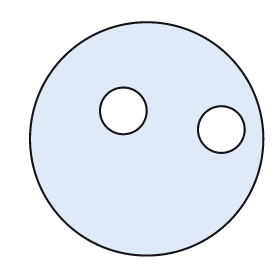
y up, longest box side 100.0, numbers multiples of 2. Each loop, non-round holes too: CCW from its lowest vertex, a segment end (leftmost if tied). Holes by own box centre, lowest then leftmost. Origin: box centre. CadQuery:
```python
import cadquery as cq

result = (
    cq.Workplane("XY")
    .moveTo(0.0, 0.0)
    .circle(50.0)
    .moveTo(32.0, 4.0)
    .circle(10.0)
    .moveTo(-10.0, 12.0)
    .circle(10.0)
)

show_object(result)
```